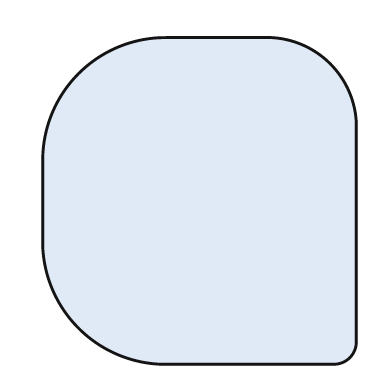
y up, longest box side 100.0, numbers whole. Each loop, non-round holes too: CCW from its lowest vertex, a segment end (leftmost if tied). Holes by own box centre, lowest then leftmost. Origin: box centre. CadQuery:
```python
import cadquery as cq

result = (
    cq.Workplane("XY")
    .moveTo(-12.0, -50.0)
    .lineTo(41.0, -50.0)
    .threePointArc((46.0, -48.0), (48.0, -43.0))
    .lineTo(48.0, 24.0)
    .threePointArc((40.0, 42.0), (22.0, 50.0))
    .lineTo(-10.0, 50.0)
    .threePointArc((-37.0, 39.0), (-48.0, 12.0))
    .lineTo(-48.0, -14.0)
    .threePointArc((-37.0, -39.0), (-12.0, -50.0))
    .close()
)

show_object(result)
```